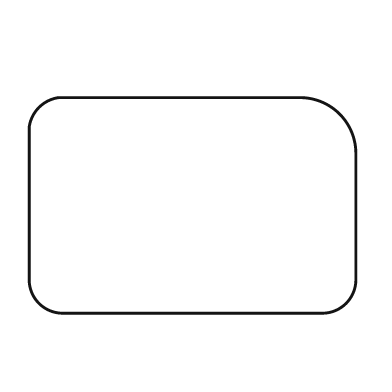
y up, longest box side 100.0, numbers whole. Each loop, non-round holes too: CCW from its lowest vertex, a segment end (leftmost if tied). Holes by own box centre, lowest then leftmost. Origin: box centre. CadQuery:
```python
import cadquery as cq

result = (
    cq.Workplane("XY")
    .moveTo(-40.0, -33.0)
    .lineTo(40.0, -33.0)
    .threePointArc((47.0, -30.0), (50.0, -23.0))
    .lineTo(50.0, 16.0)
    .threePointArc((45.0, 28.0), (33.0, 33.0))
    .lineTo(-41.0, 33.0)
    .threePointArc((-47.0, 30.0), (-50.0, 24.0))
    .lineTo(-50.0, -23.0)
    .threePointArc((-47.0, -30.0), (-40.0, -33.0))
    .close()
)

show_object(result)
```